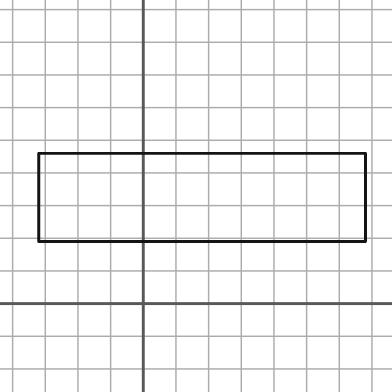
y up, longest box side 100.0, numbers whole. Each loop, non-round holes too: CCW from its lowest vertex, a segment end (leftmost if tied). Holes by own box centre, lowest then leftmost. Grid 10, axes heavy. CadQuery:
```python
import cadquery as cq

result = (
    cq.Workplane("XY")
    .moveTo(-32.0, 19.0)
    .lineTo(68.0, 19.0)
    .lineTo(68.0, 46.0)
    .lineTo(-32.0, 46.0)
    .close()
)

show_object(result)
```